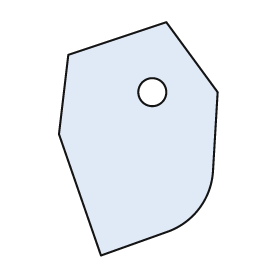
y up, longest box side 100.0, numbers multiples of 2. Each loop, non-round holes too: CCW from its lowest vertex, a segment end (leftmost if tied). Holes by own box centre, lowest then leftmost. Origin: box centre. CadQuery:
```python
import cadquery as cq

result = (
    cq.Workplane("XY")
    .moveTo(-16.0, -50.0)
    .lineTo(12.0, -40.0)
    .threePointArc((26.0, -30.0), (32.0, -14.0))
    .lineTo(34.0, 20.0)
    .lineTo(12.0, 50.0)
    .lineTo(-30.0, 36.0)
    .lineTo(-34.0, 2.0)
    .close()
    .moveTo(6.0, 20.0)
    .circle(6.0)
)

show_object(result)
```